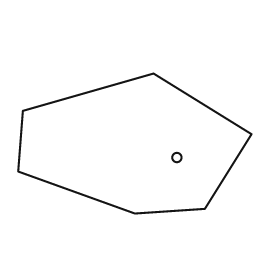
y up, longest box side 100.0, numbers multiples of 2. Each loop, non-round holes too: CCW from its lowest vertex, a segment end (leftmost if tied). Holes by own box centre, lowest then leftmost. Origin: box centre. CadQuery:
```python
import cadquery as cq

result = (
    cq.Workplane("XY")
    .moveTo(0.0, -30.0)
    .lineTo(30.0, -28.0)
    .lineTo(50.0, 4.0)
    .lineTo(8.0, 30.0)
    .lineTo(-48.0, 14.0)
    .lineTo(-50.0, -12.0)
    .close()
    .moveTo(18.0, -6.0)
    .circle(2.0)
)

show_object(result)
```